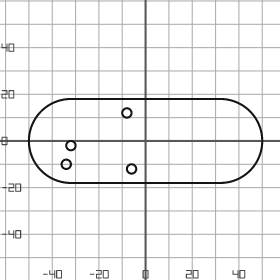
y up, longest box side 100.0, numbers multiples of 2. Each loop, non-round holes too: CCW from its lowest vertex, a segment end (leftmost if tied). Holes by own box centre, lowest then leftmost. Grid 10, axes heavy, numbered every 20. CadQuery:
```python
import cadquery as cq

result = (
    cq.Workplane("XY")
    .moveTo(-32.0, -18.0)
    .lineTo(32.0, -18.0)
    .threePointArc((50.0, 0.0), (32.0, 18.0))
    .lineTo(-32.0, 18.0)
    .threePointArc((-50.0, 0.0), (-32.0, -18.0))
    .close()
    .moveTo(-6.0, -12.0)
    .circle(2.0)
    .moveTo(-34.0, -10.0)
    .circle(2.0)
    .moveTo(-32.0, -2.0)
    .circle(2.0)
    .moveTo(-8.0, 12.0)
    .circle(2.0)
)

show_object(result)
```